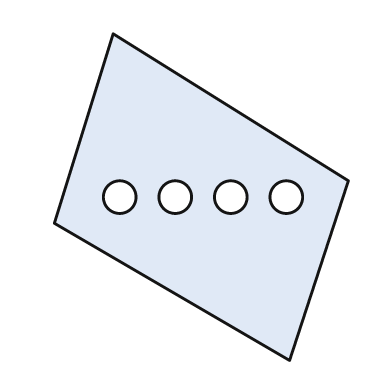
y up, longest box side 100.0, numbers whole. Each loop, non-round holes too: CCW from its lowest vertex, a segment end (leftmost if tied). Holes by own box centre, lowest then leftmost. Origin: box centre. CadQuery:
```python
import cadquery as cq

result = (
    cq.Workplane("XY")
    .moveTo(27.0, -50.0)
    .lineTo(45.0, 5.0)
    .lineTo(-27.0, 50.0)
    .lineTo(-45.0, -8.0)
    .close()
    .moveTo(-25.0, 0.0)
    .circle(5.0)
    .moveTo(-8.0, 0.0)
    .circle(5.0)
    .moveTo(9.0, 0.0)
    .circle(5.0)
    .moveTo(26.0, 0.0)
    .circle(5.0)
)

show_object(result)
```